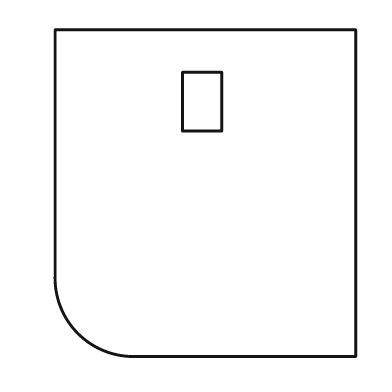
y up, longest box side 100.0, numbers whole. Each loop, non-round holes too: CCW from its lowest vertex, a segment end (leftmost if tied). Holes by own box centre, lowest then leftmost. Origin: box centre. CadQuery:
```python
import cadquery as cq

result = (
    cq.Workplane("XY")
    .moveTo(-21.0, -50.0)
    .lineTo(46.0, -50.0)
    .lineTo(46.0, 50.0)
    .lineTo(-46.0, 50.0)
    .lineTo(-46.0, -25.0)
    .threePointArc((-39.0, -43.0), (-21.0, -50.0))
    .close()
    .moveTo(-7.0, 19.0)
    .lineTo(5.0, 19.0)
    .lineTo(5.0, 37.0)
    .lineTo(-7.0, 37.0)
    .close()
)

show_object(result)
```